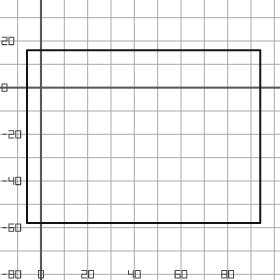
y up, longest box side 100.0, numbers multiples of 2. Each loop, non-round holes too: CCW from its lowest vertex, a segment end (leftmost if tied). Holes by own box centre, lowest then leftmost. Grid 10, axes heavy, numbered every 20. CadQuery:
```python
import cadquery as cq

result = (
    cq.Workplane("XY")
    .moveTo(-6.0, -58.0)
    .lineTo(94.0, -58.0)
    .lineTo(94.0, 16.0)
    .lineTo(-6.0, 16.0)
    .close()
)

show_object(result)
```